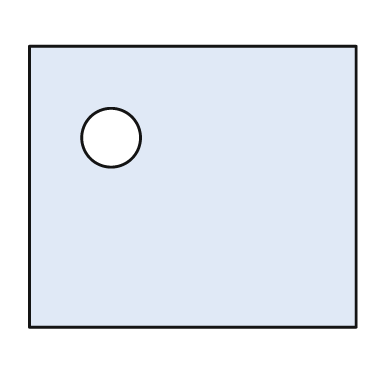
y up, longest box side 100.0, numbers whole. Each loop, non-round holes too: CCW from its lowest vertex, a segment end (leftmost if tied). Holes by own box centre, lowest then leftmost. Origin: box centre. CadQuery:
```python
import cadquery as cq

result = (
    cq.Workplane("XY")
    .moveTo(-50.0, -43.0)
    .lineTo(50.0, -43.0)
    .lineTo(50.0, 43.0)
    .lineTo(-50.0, 43.0)
    .close()
    .moveTo(-25.0, 15.0)
    .circle(9.0)
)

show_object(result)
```